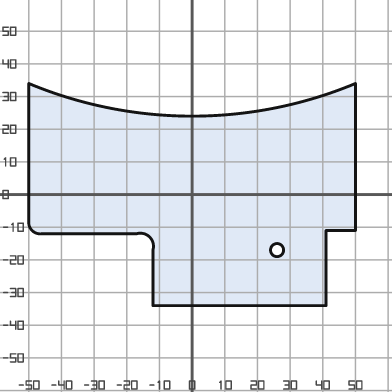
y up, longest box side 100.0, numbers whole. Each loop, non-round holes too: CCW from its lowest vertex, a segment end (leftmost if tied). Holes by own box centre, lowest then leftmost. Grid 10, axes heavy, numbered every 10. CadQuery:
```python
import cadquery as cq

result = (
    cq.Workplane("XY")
    .moveTo(-12.0, -34.0)
    .lineTo(41.0, -34.0)
    .lineTo(41.0, -11.0)
    .lineTo(50.0, -11.0)
    .lineTo(50.0, 34.0)
    .threePointArc((0.0, 24.0), (-50.0, 34.0))
    .lineTo(-50.0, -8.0)
    .threePointArc((-49.0, -11.0), (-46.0, -12.0))
    .lineTo(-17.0, -12.0)
    .threePointArc((-13.0, -13.0), (-12.0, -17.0))
    .close()
    .moveTo(26.0, -17.0)
    .circle(2.0)
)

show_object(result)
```